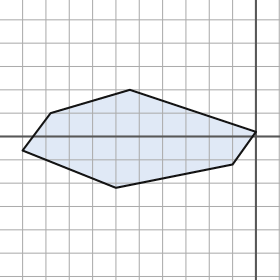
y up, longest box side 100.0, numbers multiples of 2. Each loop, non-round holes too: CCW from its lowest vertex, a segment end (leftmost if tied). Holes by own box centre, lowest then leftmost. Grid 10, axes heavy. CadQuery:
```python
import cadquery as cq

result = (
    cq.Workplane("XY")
    .moveTo(-60.0, -22.0)
    .lineTo(-10.0, -12.0)
    .lineTo(0.0, 2.0)
    .lineTo(-54.0, 20.0)
    .lineTo(-88.0, 10.0)
    .lineTo(-100.0, -6.0)
    .close()
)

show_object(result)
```